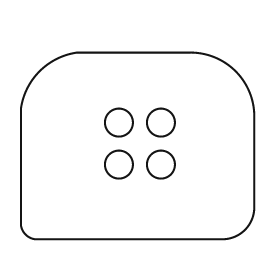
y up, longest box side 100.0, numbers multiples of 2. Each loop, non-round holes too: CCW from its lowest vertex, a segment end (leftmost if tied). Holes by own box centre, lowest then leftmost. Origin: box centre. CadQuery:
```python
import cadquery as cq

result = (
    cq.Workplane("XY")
    .moveTo(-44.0, -40.0)
    .lineTo(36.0, -40.0)
    .threePointArc((46.0, -36.0), (50.0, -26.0))
    .lineTo(50.0, 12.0)
    .threePointArc((42.0, 32.0), (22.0, 40.0))
    .lineTo(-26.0, 40.0)
    .threePointArc((-42.0, 32.0), (-50.0, 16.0))
    .lineTo(-50.0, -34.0)
    .threePointArc((-48.0, -38.0), (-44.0, -40.0))
    .close()
    .moveTo(-8.0, -8.0)
    .circle(6.0)
    .moveTo(10.0, -8.0)
    .circle(6.0)
    .moveTo(-8.0, 10.0)
    .circle(6.0)
    .moveTo(10.0, 10.0)
    .circle(6.0)
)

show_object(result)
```